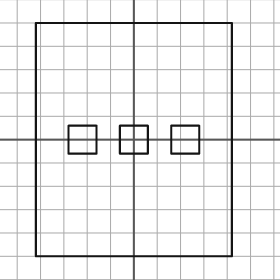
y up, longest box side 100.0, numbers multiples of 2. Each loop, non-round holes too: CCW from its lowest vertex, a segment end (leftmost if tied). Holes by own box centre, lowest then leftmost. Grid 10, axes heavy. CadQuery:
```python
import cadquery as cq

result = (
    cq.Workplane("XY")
    .moveTo(-42.0, -50.0)
    .lineTo(42.0, -50.0)
    .lineTo(42.0, 50.0)
    .lineTo(-42.0, 50.0)
    .close()
    .moveTo(-28.0, -6.0)
    .lineTo(-16.0, -6.0)
    .lineTo(-16.0, 6.0)
    .lineTo(-28.0, 6.0)
    .close()
    .moveTo(-6.0, -6.0)
    .lineTo(6.0, -6.0)
    .lineTo(6.0, 6.0)
    .lineTo(-6.0, 6.0)
    .close()
    .moveTo(16.0, -6.0)
    .lineTo(28.0, -6.0)
    .lineTo(28.0, 6.0)
    .lineTo(16.0, 6.0)
    .close()
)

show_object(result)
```